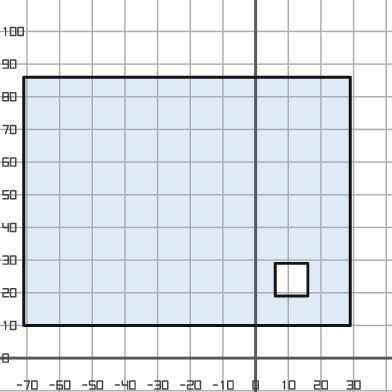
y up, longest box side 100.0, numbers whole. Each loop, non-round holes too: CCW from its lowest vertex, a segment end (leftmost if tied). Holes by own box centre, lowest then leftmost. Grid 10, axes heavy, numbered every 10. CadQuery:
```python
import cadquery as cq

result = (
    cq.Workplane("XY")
    .moveTo(-71.0, 10.0)
    .lineTo(29.0, 10.0)
    .lineTo(29.0, 86.0)
    .lineTo(-71.0, 86.0)
    .close()
    .moveTo(6.0, 19.0)
    .lineTo(16.0, 19.0)
    .lineTo(16.0, 29.0)
    .lineTo(6.0, 29.0)
    .close()
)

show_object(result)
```